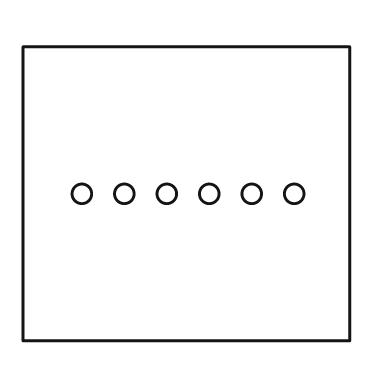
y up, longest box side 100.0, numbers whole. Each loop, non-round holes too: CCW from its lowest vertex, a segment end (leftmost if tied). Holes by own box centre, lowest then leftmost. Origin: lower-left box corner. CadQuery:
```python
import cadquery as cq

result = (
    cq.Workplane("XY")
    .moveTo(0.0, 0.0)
    .lineTo(100.0, 0.0)
    .lineTo(100.0, 90.0)
    .lineTo(0.0, 90.0)
    .close()
    .moveTo(18.0, 45.0)
    .circle(3.0)
    .moveTo(31.0, 45.0)
    .circle(3.0)
    .moveTo(44.0, 45.0)
    .circle(3.0)
    .moveTo(57.0, 45.0)
    .circle(3.0)
    .moveTo(70.0, 45.0)
    .circle(3.0)
    .moveTo(83.0, 45.0)
    .circle(3.0)
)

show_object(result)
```